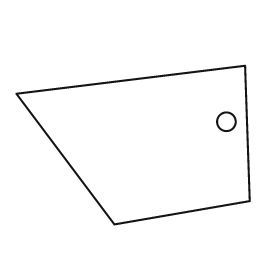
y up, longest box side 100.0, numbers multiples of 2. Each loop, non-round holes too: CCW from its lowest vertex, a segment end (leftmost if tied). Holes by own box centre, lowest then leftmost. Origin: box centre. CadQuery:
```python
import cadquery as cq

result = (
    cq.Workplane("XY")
    .moveTo(-8.0, -34.0)
    .lineTo(50.0, -24.0)
    .lineTo(48.0, 34.0)
    .lineTo(-50.0, 22.0)
    .close()
    .moveTo(40.0, 10.0)
    .circle(4.0)
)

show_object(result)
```